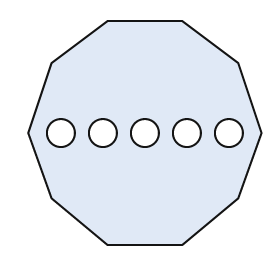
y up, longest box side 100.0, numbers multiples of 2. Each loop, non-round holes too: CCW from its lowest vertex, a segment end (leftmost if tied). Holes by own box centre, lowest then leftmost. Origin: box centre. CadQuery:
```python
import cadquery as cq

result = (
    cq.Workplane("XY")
    .moveTo(-16.0, -48.0)
    .lineTo(16.0, -48.0)
    .lineTo(40.0, -28.0)
    .lineTo(50.0, 0.0)
    .lineTo(40.0, 30.0)
    .lineTo(16.0, 48.0)
    .lineTo(-16.0, 48.0)
    .lineTo(-40.0, 30.0)
    .lineTo(-50.0, 0.0)
    .lineTo(-40.0, -28.0)
    .close()
    .moveTo(-36.0, 0.0)
    .circle(6.0)
    .moveTo(-18.0, 0.0)
    .circle(6.0)
    .moveTo(0.0, 0.0)
    .circle(6.0)
    .moveTo(18.0, 0.0)
    .circle(6.0)
    .moveTo(36.0, 0.0)
    .circle(6.0)
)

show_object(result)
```